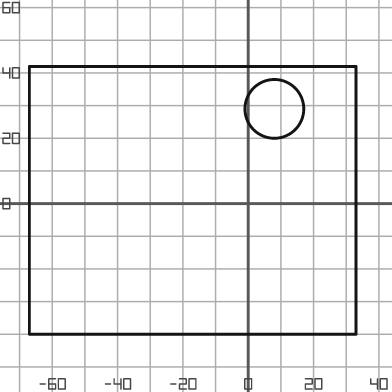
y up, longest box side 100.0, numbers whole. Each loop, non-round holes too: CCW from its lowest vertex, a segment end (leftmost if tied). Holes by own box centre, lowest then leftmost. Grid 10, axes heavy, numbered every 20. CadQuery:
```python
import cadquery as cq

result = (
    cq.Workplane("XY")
    .moveTo(-67.0, -40.0)
    .lineTo(33.0, -40.0)
    .lineTo(33.0, 42.0)
    .lineTo(-67.0, 42.0)
    .close()
    .moveTo(8.0, 29.0)
    .circle(9.0)
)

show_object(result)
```